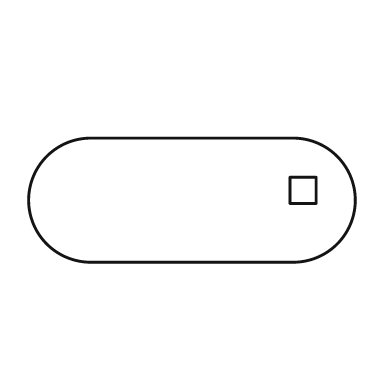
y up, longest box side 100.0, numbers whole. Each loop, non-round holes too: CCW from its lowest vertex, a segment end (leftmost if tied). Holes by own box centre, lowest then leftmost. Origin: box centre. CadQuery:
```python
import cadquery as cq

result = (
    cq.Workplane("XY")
    .moveTo(-31.0, -19.0)
    .lineTo(31.0, -19.0)
    .threePointArc((50.0, 0.0), (31.0, 19.0))
    .lineTo(-31.0, 19.0)
    .threePointArc((-50.0, 0.0), (-31.0, -19.0))
    .close()
    .moveTo(30.0, -1.0)
    .lineTo(38.0, -1.0)
    .lineTo(38.0, 7.0)
    .lineTo(30.0, 7.0)
    .close()
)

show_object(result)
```